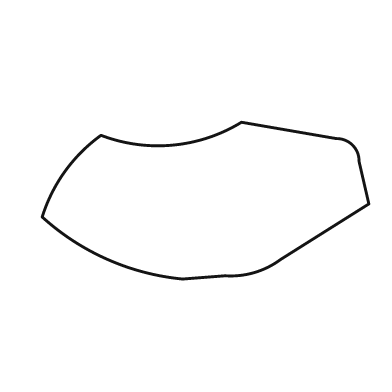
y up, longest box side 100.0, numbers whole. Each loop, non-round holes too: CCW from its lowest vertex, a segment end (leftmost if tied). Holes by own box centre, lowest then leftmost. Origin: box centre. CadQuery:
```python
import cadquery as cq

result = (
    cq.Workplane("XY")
    .moveTo(-7.0, -24.0)
    .lineTo(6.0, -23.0)
    .threePointArc((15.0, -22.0), (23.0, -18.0))
    .lineTo(50.0, -1.0)
    .lineTo(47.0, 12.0)
    .threePointArc((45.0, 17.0), (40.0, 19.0))
    .lineTo(11.0, 24.0)
    .threePointArc((-10.0, 17.0), (-32.0, 20.0))
    .threePointArc((-43.0, 9.0), (-50.0, -5.0))
    .threePointArc((-30.0, -18.0), (-7.0, -24.0))
    .close()
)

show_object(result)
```